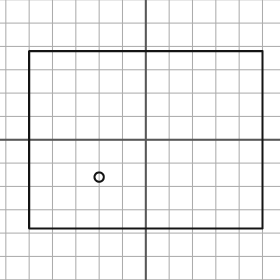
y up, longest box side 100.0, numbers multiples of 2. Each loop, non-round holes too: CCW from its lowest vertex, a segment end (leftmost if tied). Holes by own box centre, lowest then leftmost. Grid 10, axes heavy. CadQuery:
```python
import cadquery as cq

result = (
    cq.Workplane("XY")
    .moveTo(-50.0, -38.0)
    .lineTo(50.0, -38.0)
    .lineTo(50.0, 38.0)
    .lineTo(-50.0, 38.0)
    .close()
    .moveTo(-20.0, -16.0)
    .circle(2.0)
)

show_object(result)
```